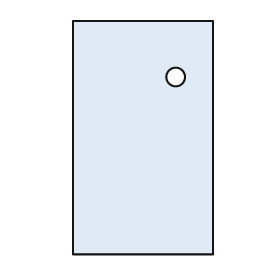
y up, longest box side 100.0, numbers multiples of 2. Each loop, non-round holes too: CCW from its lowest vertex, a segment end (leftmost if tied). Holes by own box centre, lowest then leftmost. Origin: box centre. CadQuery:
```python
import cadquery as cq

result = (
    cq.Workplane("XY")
    .moveTo(-30.0, -50.0)
    .lineTo(30.0, -50.0)
    .lineTo(30.0, 50.0)
    .lineTo(-30.0, 50.0)
    .close()
    .moveTo(14.0, 26.0)
    .circle(4.0)
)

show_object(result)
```